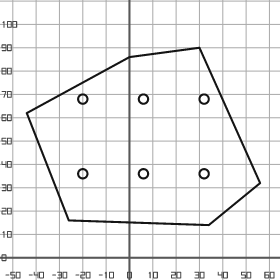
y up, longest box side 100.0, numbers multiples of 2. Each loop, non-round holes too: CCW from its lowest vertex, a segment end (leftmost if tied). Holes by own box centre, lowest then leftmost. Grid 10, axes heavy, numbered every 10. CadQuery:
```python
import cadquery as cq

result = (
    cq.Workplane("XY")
    .moveTo(34.0, 14.0)
    .lineTo(56.0, 32.0)
    .lineTo(30.0, 90.0)
    .lineTo(0.0, 86.0)
    .lineTo(-44.0, 62.0)
    .lineTo(-26.0, 16.0)
    .close()
    .moveTo(-20.0, 36.0)
    .circle(2.0)
    .moveTo(6.0, 36.0)
    .circle(2.0)
    .moveTo(32.0, 36.0)
    .circle(2.0)
    .moveTo(-20.0, 68.0)
    .circle(2.0)
    .moveTo(6.0, 68.0)
    .circle(2.0)
    .moveTo(32.0, 68.0)
    .circle(2.0)
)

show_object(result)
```